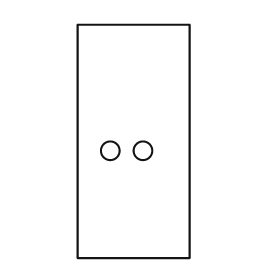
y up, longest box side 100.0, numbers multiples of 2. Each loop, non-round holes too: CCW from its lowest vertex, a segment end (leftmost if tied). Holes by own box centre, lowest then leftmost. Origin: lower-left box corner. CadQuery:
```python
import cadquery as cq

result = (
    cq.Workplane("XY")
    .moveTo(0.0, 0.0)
    .lineTo(48.0, 0.0)
    .lineTo(48.0, 100.0)
    .lineTo(0.0, 100.0)
    .close()
    .moveTo(14.0, 46.0)
    .circle(4.0)
    .moveTo(28.0, 46.0)
    .circle(4.0)
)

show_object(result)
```